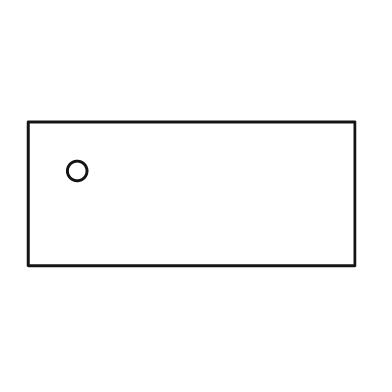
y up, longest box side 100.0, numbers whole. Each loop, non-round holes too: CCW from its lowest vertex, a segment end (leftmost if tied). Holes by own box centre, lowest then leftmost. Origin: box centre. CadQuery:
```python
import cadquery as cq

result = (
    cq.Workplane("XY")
    .moveTo(-50.0, -22.0)
    .lineTo(50.0, -22.0)
    .lineTo(50.0, 22.0)
    .lineTo(-50.0, 22.0)
    .close()
    .moveTo(-35.0, 7.0)
    .circle(3.0)
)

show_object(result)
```